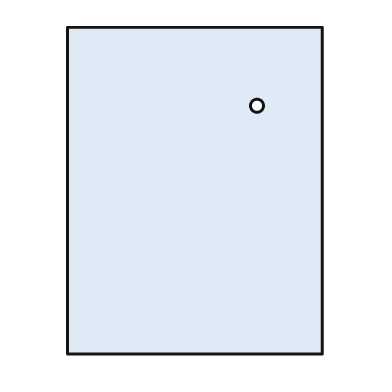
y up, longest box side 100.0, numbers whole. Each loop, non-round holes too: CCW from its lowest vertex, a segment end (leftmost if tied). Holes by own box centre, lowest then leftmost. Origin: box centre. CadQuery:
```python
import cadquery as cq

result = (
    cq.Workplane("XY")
    .moveTo(-39.0, -50.0)
    .lineTo(39.0, -50.0)
    .lineTo(39.0, 50.0)
    .lineTo(-39.0, 50.0)
    .close()
    .moveTo(19.0, 26.0)
    .circle(2.0)
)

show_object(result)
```